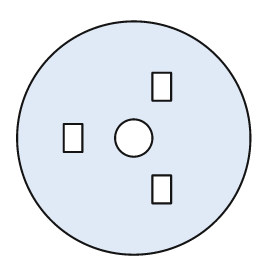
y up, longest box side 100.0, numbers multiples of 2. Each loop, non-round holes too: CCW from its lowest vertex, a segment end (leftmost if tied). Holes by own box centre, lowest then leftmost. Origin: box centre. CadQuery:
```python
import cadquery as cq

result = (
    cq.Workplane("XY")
    .moveTo(0.0, 0.0)
    .circle(50.0)
    .moveTo(8.0, -28.0)
    .lineTo(16.0, -28.0)
    .lineTo(16.0, -16.0)
    .lineTo(8.0, -16.0)
    .close()
    .moveTo(-30.0, -6.0)
    .lineTo(-22.0, -6.0)
    .lineTo(-22.0, 6.0)
    .lineTo(-30.0, 6.0)
    .close()
    .moveTo(0.0, 0.0)
    .circle(8.0)
    .moveTo(8.0, 16.0)
    .lineTo(16.0, 16.0)
    .lineTo(16.0, 28.0)
    .lineTo(8.0, 28.0)
    .close()
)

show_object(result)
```